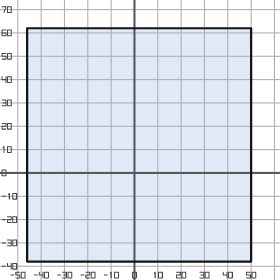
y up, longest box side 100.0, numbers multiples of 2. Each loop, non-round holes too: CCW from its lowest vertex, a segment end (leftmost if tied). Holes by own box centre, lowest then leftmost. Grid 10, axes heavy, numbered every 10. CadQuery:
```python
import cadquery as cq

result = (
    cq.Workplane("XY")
    .moveTo(-46.0, -38.0)
    .lineTo(50.0, -38.0)
    .lineTo(50.0, 62.0)
    .lineTo(-46.0, 62.0)
    .close()
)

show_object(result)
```